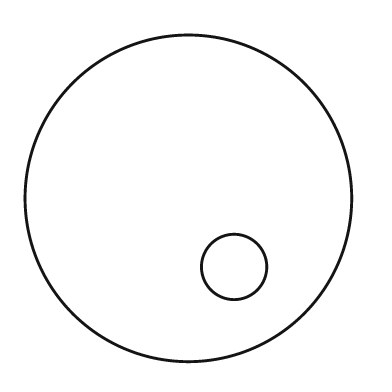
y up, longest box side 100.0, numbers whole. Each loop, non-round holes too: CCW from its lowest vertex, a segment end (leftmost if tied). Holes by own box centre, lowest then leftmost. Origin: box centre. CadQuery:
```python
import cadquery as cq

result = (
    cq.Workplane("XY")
    .moveTo(0.0, 0.0)
    .circle(50.0)
    .moveTo(14.0, -21.0)
    .circle(10.0)
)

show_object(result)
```